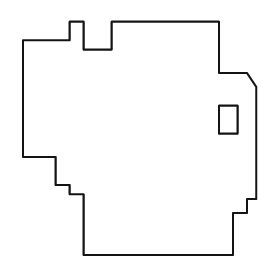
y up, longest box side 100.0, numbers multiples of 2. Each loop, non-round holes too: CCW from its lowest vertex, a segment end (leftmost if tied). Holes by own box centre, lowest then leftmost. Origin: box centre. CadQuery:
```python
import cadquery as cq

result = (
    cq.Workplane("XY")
    .moveTo(-24.0, -50.0)
    .lineTo(40.0, -50.0)
    .lineTo(40.0, -32.0)
    .lineTo(46.0, -32.0)
    .lineTo(46.0, -26.0)
    .lineTo(50.0, -26.0)
    .lineTo(50.0, 22.0)
    .lineTo(46.0, 28.0)
    .lineTo(34.0, 28.0)
    .lineTo(34.0, 50.0)
    .lineTo(-12.0, 50.0)
    .lineTo(-12.0, 38.0)
    .lineTo(-24.0, 38.0)
    .lineTo(-24.0, 50.0)
    .lineTo(-30.0, 50.0)
    .lineTo(-30.0, 42.0)
    .lineTo(-50.0, 42.0)
    .lineTo(-50.0, -8.0)
    .lineTo(-36.0, -8.0)
    .lineTo(-36.0, -20.0)
    .lineTo(-30.0, -20.0)
    .lineTo(-30.0, -24.0)
    .lineTo(-24.0, -24.0)
    .close()
    .moveTo(34.0, 2.0)
    .lineTo(42.0, 2.0)
    .lineTo(42.0, 14.0)
    .lineTo(34.0, 14.0)
    .close()
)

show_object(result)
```